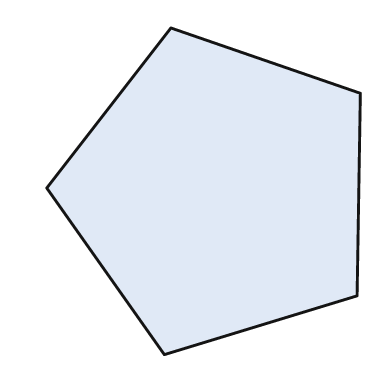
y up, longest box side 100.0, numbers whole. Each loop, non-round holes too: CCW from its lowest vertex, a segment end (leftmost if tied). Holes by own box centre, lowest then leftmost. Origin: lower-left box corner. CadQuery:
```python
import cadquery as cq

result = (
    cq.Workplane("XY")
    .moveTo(36.0, 0.0)
    .lineTo(95.0, 18.0)
    .lineTo(96.0, 80.0)
    .lineTo(38.0, 100.0)
    .lineTo(0.0, 51.0)
    .close()
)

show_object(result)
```